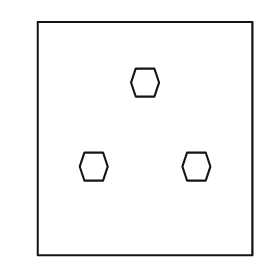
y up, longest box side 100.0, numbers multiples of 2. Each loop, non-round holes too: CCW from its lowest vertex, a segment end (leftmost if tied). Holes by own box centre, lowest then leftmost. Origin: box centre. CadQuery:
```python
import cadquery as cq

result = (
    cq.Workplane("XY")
    .moveTo(-46.0, -50.0)
    .lineTo(46.0, -50.0)
    .lineTo(46.0, 50.0)
    .lineTo(-46.0, 50.0)
    .close()
    .moveTo(-26.0, -18.0)
    .lineTo(-18.0, -18.0)
    .lineTo(-16.0, -12.0)
    .lineTo(-18.0, -6.0)
    .lineTo(-26.0, -6.0)
    .lineTo(-28.0, -12.0)
    .close()
    .moveTo(18.0, -18.0)
    .lineTo(26.0, -18.0)
    .lineTo(28.0, -12.0)
    .lineTo(26.0, -6.0)
    .lineTo(18.0, -6.0)
    .lineTo(16.0, -12.0)
    .close()
    .moveTo(-4.0, 18.0)
    .lineTo(4.0, 18.0)
    .lineTo(6.0, 24.0)
    .lineTo(4.0, 30.0)
    .lineTo(-4.0, 30.0)
    .lineTo(-6.0, 24.0)
    .close()
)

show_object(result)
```